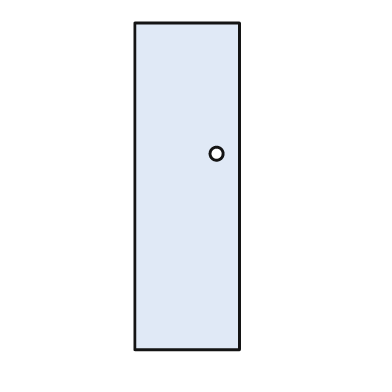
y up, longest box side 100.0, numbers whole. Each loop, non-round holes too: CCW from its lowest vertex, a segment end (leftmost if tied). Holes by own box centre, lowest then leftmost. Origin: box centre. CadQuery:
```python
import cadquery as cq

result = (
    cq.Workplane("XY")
    .moveTo(-16.0, -50.0)
    .lineTo(16.0, -50.0)
    .lineTo(16.0, 50.0)
    .lineTo(-16.0, 50.0)
    .close()
    .moveTo(9.0, 10.0)
    .circle(2.0)
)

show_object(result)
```